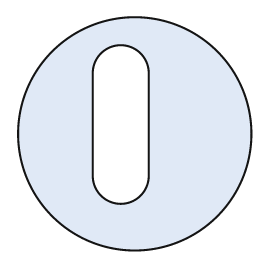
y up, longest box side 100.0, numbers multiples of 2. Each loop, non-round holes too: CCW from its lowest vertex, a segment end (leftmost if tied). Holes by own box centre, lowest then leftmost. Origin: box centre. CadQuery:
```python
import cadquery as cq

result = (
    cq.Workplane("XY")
    .moveTo(0.0, 0.0)
    .circle(50.0)
    .moveTo(-18.0, -18.0)
    .threePointArc((-6.0, -30.0), (6.0, -18.0))
    .lineTo(6.0, 26.0)
    .threePointArc((-6.0, 38.0), (-18.0, 26.0))
    .close()
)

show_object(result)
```